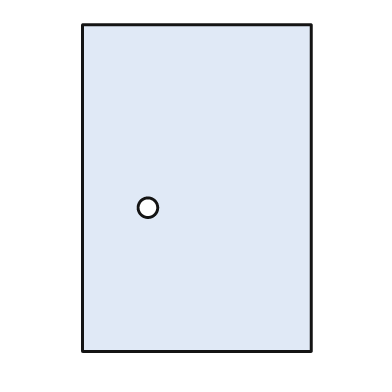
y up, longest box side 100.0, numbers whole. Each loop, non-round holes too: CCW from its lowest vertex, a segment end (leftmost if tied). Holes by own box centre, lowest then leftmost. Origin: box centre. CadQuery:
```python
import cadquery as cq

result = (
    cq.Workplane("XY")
    .moveTo(-35.0, -50.0)
    .lineTo(35.0, -50.0)
    .lineTo(35.0, 50.0)
    .lineTo(-35.0, 50.0)
    .close()
    .moveTo(-15.0, -6.0)
    .circle(3.0)
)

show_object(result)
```